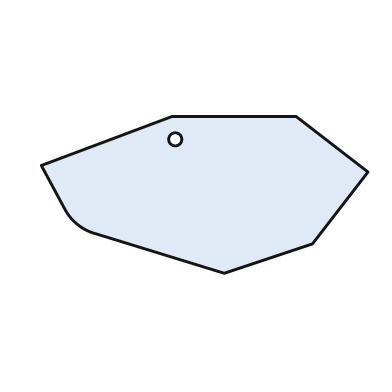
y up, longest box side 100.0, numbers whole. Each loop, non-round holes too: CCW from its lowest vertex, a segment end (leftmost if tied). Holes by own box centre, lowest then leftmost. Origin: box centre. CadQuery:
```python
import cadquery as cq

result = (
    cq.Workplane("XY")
    .moveTo(6.0, -24.0)
    .lineTo(33.0, -15.0)
    .lineTo(50.0, 7.0)
    .lineTo(28.0, 24.0)
    .lineTo(-10.0, 24.0)
    .lineTo(-50.0, 9.0)
    .lineTo(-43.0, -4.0)
    .threePointArc((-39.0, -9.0), (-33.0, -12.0))
    .close()
    .moveTo(-9.0, 17.0)
    .circle(2.0)
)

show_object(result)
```